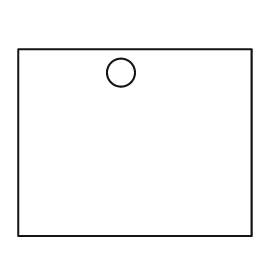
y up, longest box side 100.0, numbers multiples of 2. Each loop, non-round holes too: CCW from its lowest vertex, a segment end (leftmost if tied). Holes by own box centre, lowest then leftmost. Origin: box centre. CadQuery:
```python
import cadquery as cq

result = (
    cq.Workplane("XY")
    .moveTo(-50.0, -40.0)
    .lineTo(50.0, -40.0)
    .lineTo(50.0, 40.0)
    .lineTo(-50.0, 40.0)
    .close()
    .moveTo(-6.0, 30.0)
    .circle(6.0)
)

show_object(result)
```